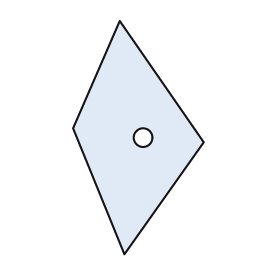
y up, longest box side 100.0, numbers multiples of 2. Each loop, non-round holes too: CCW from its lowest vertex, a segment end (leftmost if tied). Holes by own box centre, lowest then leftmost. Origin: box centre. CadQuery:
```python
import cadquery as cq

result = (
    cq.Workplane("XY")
    .moveTo(-6.0, -50.0)
    .lineTo(28.0, -2.0)
    .lineTo(-8.0, 50.0)
    .lineTo(-28.0, 4.0)
    .close()
    .moveTo(2.0, 0.0)
    .circle(4.0)
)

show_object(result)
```